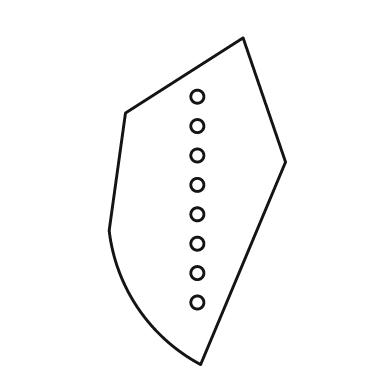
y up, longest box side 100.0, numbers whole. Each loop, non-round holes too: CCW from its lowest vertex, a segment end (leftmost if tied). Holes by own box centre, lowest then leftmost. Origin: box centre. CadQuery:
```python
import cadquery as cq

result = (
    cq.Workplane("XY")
    .moveTo(1.0, -50.0)
    .lineTo(27.0, 12.0)
    .lineTo(14.0, 50.0)
    .lineTo(-22.0, 27.0)
    .lineTo(-27.0, -9.0)
    .threePointArc((-18.0, -33.0), (1.0, -50.0))
    .close()
    .moveTo(0.0, -31.0)
    .circle(2.0)
    .moveTo(0.0, -22.0)
    .circle(2.0)
    .moveTo(0.0, -13.0)
    .circle(2.0)
    .moveTo(0.0, -4.0)
    .circle(2.0)
    .moveTo(0.0, 5.0)
    .circle(2.0)
    .moveTo(0.0, 14.0)
    .circle(2.0)
    .moveTo(0.0, 23.0)
    .circle(2.0)
    .moveTo(0.0, 32.0)
    .circle(2.0)
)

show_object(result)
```